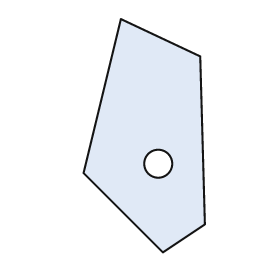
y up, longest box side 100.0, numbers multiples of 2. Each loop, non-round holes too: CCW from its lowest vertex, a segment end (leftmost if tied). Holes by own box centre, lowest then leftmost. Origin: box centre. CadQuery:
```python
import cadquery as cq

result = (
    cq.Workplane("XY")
    .moveTo(8.0, -50.0)
    .lineTo(26.0, -38.0)
    .lineTo(24.0, 34.0)
    .lineTo(-10.0, 50.0)
    .lineTo(-26.0, -16.0)
    .close()
    .moveTo(6.0, -12.0)
    .circle(6.0)
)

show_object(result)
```